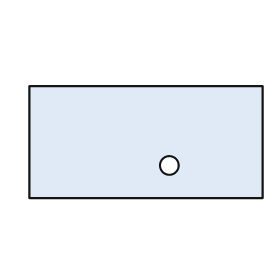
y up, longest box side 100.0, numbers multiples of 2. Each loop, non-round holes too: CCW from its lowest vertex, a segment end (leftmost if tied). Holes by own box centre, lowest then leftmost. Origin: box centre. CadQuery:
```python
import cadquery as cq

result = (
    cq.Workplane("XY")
    .moveTo(-50.0, -24.0)
    .lineTo(50.0, -24.0)
    .lineTo(50.0, 24.0)
    .lineTo(-50.0, 24.0)
    .close()
    .moveTo(10.0, -10.0)
    .circle(4.0)
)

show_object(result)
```